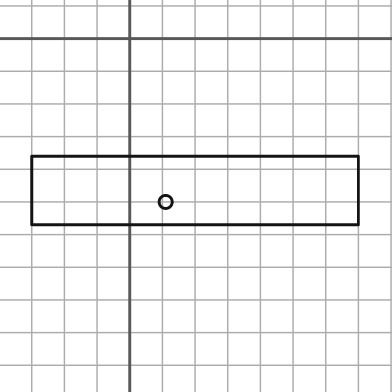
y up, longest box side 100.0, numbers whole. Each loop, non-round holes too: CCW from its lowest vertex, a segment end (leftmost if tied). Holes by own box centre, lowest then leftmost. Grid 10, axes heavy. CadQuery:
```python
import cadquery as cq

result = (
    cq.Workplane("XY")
    .moveTo(-30.0, -57.0)
    .lineTo(70.0, -57.0)
    .lineTo(70.0, -36.0)
    .lineTo(-30.0, -36.0)
    .close()
    .moveTo(11.0, -50.0)
    .circle(2.0)
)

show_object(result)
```